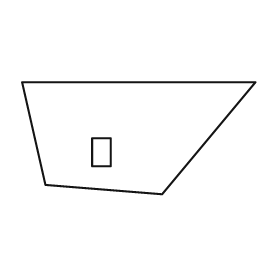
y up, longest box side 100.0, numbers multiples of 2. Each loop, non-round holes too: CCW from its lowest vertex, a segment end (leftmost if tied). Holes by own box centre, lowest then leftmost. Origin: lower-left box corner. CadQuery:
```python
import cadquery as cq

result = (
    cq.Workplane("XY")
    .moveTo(60.0, 0.0)
    .lineTo(100.0, 48.0)
    .lineTo(0.0, 48.0)
    .lineTo(10.0, 4.0)
    .close()
    .moveTo(30.0, 12.0)
    .lineTo(38.0, 12.0)
    .lineTo(38.0, 24.0)
    .lineTo(30.0, 24.0)
    .close()
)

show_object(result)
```